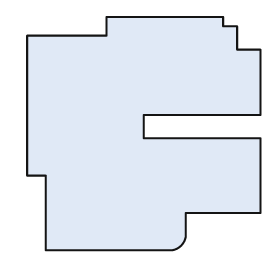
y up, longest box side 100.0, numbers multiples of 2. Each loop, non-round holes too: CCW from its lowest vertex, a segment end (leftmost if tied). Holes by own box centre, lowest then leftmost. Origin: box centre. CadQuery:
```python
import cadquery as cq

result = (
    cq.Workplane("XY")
    .moveTo(-42.0, -50.0)
    .lineTo(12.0, -50.0)
    .threePointArc((16.0, -48.0), (18.0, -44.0))
    .lineTo(18.0, -34.0)
    .lineTo(50.0, -34.0)
    .lineTo(50.0, -2.0)
    .lineTo(0.0, -2.0)
    .lineTo(0.0, 8.0)
    .lineTo(50.0, 8.0)
    .lineTo(50.0, 36.0)
    .lineTo(40.0, 36.0)
    .lineTo(40.0, 46.0)
    .lineTo(34.0, 46.0)
    .lineTo(34.0, 50.0)
    .lineTo(-16.0, 50.0)
    .lineTo(-16.0, 42.0)
    .lineTo(-50.0, 42.0)
    .lineTo(-50.0, -18.0)
    .lineTo(-42.0, -18.0)
    .close()
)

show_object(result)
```